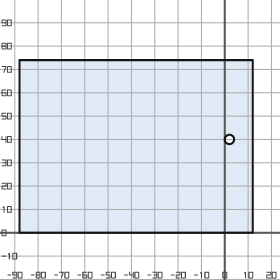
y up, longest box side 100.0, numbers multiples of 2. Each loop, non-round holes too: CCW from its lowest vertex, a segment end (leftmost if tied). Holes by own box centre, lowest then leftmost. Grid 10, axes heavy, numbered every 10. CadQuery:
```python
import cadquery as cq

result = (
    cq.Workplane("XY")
    .moveTo(-88.0, 0.0)
    .lineTo(12.0, 0.0)
    .lineTo(12.0, 74.0)
    .lineTo(-88.0, 74.0)
    .close()
    .moveTo(2.0, 40.0)
    .circle(2.0)
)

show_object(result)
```